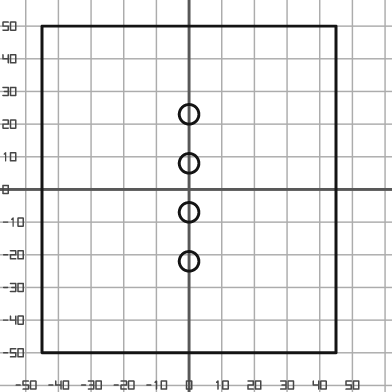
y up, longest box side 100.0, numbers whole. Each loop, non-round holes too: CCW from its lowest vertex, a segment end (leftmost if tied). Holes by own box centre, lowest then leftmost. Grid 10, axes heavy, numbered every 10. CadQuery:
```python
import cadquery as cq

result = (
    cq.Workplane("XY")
    .moveTo(-45.0, -50.0)
    .lineTo(45.0, -50.0)
    .lineTo(45.0, 50.0)
    .lineTo(-45.0, 50.0)
    .close()
    .moveTo(0.0, -22.0)
    .circle(3.0)
    .moveTo(0.0, -7.0)
    .circle(3.0)
    .moveTo(0.0, 8.0)
    .circle(3.0)
    .moveTo(0.0, 23.0)
    .circle(3.0)
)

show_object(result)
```